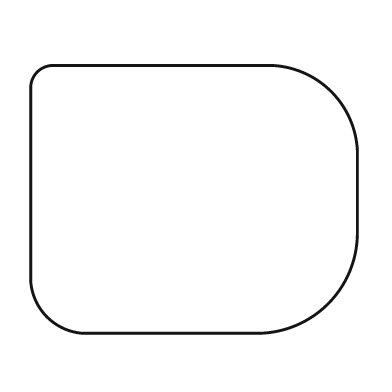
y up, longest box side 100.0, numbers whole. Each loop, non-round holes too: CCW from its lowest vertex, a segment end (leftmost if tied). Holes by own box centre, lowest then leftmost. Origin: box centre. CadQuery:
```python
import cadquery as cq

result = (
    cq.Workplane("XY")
    .moveTo(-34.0, -41.0)
    .lineTo(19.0, -41.0)
    .threePointArc((41.0, -32.0), (50.0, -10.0))
    .lineTo(50.0, 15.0)
    .threePointArc((42.0, 33.0), (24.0, 41.0))
    .lineTo(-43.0, 41.0)
    .threePointArc((-48.0, 39.0), (-50.0, 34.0))
    .lineTo(-50.0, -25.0)
    .threePointArc((-45.0, -36.0), (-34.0, -41.0))
    .close()
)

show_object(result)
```